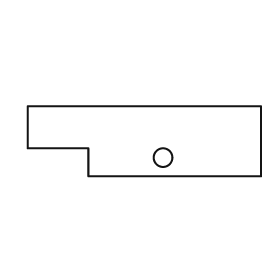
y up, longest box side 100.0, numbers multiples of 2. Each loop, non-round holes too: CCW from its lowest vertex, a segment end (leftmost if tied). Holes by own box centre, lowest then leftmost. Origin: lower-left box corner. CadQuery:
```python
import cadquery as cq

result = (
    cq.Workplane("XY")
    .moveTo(26.0, 0.0)
    .lineTo(100.0, 0.0)
    .lineTo(100.0, 30.0)
    .lineTo(0.0, 30.0)
    .lineTo(0.0, 12.0)
    .lineTo(26.0, 12.0)
    .close()
    .moveTo(58.0, 8.0)
    .circle(4.0)
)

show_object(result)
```